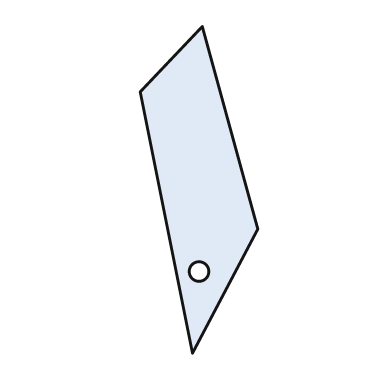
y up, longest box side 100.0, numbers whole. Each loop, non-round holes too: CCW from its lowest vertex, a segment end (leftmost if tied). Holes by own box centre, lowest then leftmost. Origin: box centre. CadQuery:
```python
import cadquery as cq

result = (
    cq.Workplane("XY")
    .moveTo(-2.0, -50.0)
    .lineTo(18.0, -12.0)
    .lineTo(1.0, 50.0)
    .lineTo(-18.0, 30.0)
    .close()
    .moveTo(0.0, -25.0)
    .circle(3.0)
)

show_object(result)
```